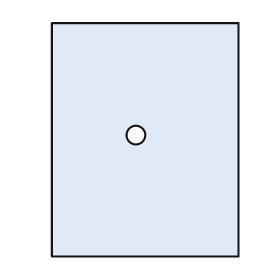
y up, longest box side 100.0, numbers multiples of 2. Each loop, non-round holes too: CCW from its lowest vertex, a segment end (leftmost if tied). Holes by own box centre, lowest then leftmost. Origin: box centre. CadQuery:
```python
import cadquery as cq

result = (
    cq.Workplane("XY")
    .moveTo(-40.0, -50.0)
    .lineTo(40.0, -50.0)
    .lineTo(40.0, 50.0)
    .lineTo(-40.0, 50.0)
    .close()
    .moveTo(-4.0, 2.0)
    .circle(4.0)
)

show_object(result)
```